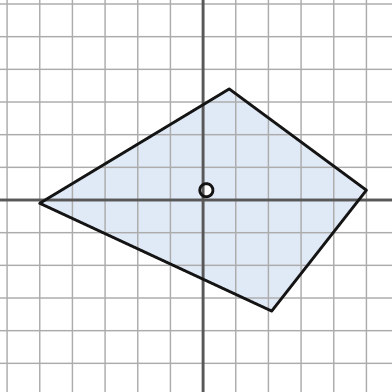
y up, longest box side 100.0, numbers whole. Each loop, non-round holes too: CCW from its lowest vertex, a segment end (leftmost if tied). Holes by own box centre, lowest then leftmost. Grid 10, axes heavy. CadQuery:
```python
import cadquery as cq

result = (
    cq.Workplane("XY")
    .moveTo(21.0, -34.0)
    .lineTo(50.0, 3.0)
    .lineTo(8.0, 34.0)
    .lineTo(-50.0, -1.0)
    .close()
    .moveTo(1.0, 3.0)
    .circle(2.0)
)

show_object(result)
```